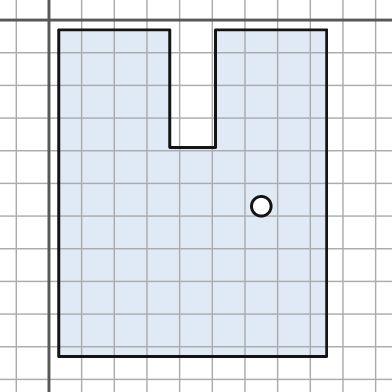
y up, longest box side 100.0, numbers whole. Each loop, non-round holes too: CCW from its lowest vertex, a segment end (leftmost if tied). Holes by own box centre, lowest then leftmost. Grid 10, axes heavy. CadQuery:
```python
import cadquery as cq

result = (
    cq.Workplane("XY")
    .moveTo(3.0, -103.0)
    .lineTo(85.0, -103.0)
    .lineTo(85.0, -3.0)
    .lineTo(51.0, -3.0)
    .lineTo(51.0, -39.0)
    .lineTo(37.0, -39.0)
    .lineTo(37.0, -3.0)
    .lineTo(3.0, -3.0)
    .close()
    .moveTo(65.0, -57.0)
    .circle(3.0)
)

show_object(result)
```